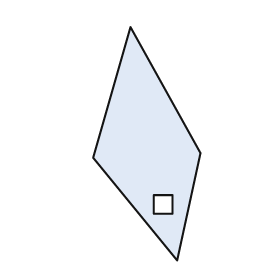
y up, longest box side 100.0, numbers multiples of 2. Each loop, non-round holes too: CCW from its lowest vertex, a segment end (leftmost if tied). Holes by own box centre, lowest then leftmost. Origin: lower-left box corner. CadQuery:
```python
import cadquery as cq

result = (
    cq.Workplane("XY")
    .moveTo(36.0, 0.0)
    .lineTo(46.0, 46.0)
    .lineTo(16.0, 100.0)
    .lineTo(0.0, 44.0)
    .close()
    .moveTo(26.0, 20.0)
    .lineTo(34.0, 20.0)
    .lineTo(34.0, 28.0)
    .lineTo(26.0, 28.0)
    .close()
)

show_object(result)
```